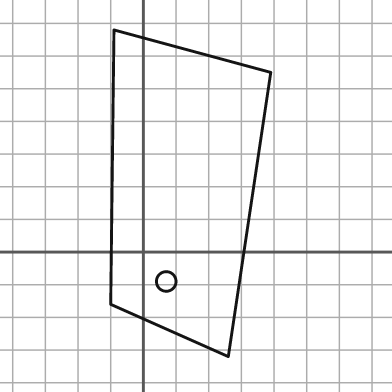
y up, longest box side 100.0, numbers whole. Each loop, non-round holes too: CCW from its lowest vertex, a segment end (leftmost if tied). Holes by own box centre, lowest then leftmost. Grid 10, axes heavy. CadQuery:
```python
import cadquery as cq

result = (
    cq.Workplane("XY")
    .moveTo(26.0, -32.0)
    .lineTo(39.0, 55.0)
    .lineTo(-9.0, 68.0)
    .lineTo(-10.0, -16.0)
    .close()
    .moveTo(7.0, -9.0)
    .circle(3.0)
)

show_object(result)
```